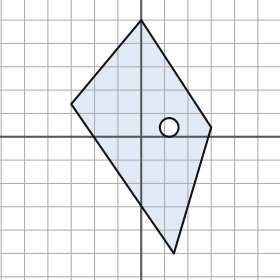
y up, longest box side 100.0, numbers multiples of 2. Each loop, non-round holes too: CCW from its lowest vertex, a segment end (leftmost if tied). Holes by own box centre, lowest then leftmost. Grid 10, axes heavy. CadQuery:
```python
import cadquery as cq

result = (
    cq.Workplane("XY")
    .moveTo(14.0, -50.0)
    .lineTo(30.0, 4.0)
    .lineTo(0.0, 50.0)
    .lineTo(-30.0, 14.0)
    .close()
    .moveTo(12.0, 4.0)
    .circle(4.0)
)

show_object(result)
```